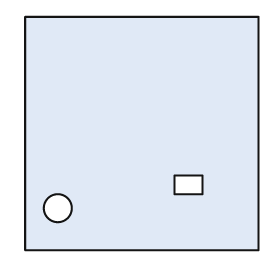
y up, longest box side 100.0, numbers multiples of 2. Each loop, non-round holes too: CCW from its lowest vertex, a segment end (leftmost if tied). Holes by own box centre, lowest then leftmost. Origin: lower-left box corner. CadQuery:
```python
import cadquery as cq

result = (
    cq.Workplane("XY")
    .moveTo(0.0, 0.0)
    .lineTo(100.0, 0.0)
    .lineTo(100.0, 100.0)
    .lineTo(0.0, 100.0)
    .close()
    .moveTo(14.0, 18.0)
    .circle(6.0)
    .moveTo(64.0, 24.0)
    .lineTo(76.0, 24.0)
    .lineTo(76.0, 32.0)
    .lineTo(64.0, 32.0)
    .close()
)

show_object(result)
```